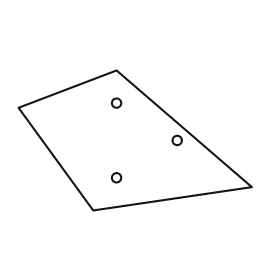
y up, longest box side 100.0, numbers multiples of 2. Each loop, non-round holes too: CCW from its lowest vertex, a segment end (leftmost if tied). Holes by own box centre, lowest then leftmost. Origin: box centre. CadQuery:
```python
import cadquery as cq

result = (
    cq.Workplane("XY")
    .moveTo(-18.0, -30.0)
    .lineTo(50.0, -20.0)
    .lineTo(-8.0, 30.0)
    .lineTo(-50.0, 14.0)
    .close()
    .moveTo(-8.0, -16.0)
    .circle(2.0)
    .moveTo(18.0, 0.0)
    .circle(2.0)
    .moveTo(-8.0, 16.0)
    .circle(2.0)
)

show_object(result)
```